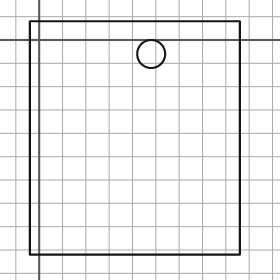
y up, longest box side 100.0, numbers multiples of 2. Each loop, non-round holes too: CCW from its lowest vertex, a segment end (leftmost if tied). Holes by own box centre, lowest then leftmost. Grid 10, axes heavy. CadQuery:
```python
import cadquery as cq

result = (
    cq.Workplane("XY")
    .moveTo(-4.0, -92.0)
    .lineTo(86.0, -92.0)
    .lineTo(86.0, 8.0)
    .lineTo(-4.0, 8.0)
    .close()
    .moveTo(48.0, -6.0)
    .circle(6.0)
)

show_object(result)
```